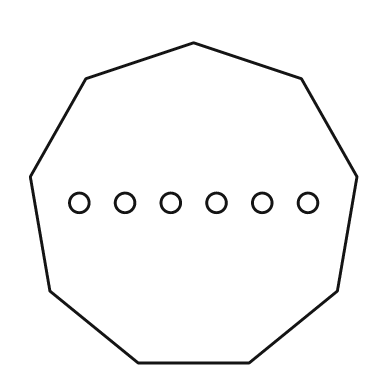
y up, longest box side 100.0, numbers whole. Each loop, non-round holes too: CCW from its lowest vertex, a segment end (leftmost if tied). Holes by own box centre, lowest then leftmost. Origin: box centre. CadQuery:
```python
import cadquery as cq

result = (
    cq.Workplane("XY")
    .moveTo(-17.0, -49.0)
    .lineTo(17.0, -49.0)
    .lineTo(44.0, -27.0)
    .lineTo(50.0, 8.0)
    .lineTo(33.0, 38.0)
    .lineTo(0.0, 49.0)
    .lineTo(-33.0, 38.0)
    .lineTo(-50.0, 8.0)
    .lineTo(-44.0, -27.0)
    .close()
    .moveTo(-35.0, 0.0)
    .circle(3.0)
    .moveTo(-21.0, 0.0)
    .circle(3.0)
    .moveTo(-7.0, 0.0)
    .circle(3.0)
    .moveTo(7.0, 0.0)
    .circle(3.0)
    .moveTo(21.0, 0.0)
    .circle(3.0)
    .moveTo(35.0, 0.0)
    .circle(3.0)
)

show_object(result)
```